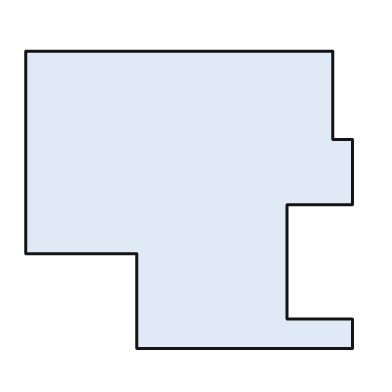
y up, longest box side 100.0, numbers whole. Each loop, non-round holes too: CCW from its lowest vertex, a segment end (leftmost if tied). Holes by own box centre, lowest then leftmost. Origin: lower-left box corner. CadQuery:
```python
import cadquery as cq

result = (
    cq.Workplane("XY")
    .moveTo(34.0, 0.0)
    .lineTo(100.0, 0.0)
    .lineTo(100.0, 9.0)
    .lineTo(80.0, 9.0)
    .lineTo(80.0, 44.0)
    .lineTo(100.0, 44.0)
    .lineTo(100.0, 64.0)
    .lineTo(94.0, 64.0)
    .lineTo(94.0, 91.0)
    .lineTo(0.0, 91.0)
    .lineTo(0.0, 29.0)
    .lineTo(34.0, 29.0)
    .close()
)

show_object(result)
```